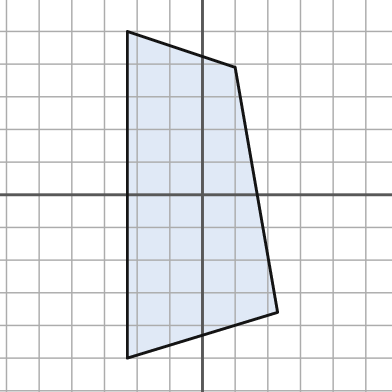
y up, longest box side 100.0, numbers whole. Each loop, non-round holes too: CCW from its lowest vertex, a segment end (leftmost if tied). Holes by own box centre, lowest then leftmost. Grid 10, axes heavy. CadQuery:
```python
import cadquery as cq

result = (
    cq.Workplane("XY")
    .moveTo(-23.0, -50.0)
    .lineTo(23.0, -36.0)
    .lineTo(10.0, 39.0)
    .lineTo(-23.0, 50.0)
    .close()
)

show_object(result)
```